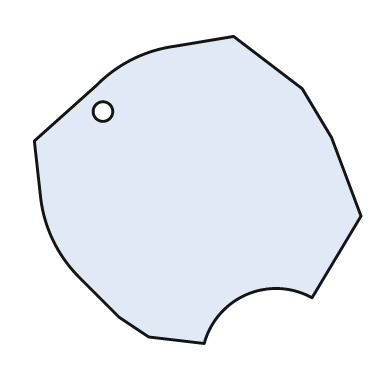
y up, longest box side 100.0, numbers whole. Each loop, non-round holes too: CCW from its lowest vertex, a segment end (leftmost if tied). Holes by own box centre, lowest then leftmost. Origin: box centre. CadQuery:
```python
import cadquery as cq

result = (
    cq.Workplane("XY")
    .moveTo(2.0, -47.0)
    .threePointArc((15.0, -32.0), (35.0, -33.0))
    .lineTo(50.0, -8.0)
    .lineTo(41.0, 16.0)
    .lineTo(32.0, 31.0)
    .lineTo(11.0, 47.0)
    .lineTo(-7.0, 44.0)
    .threePointArc((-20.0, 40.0), (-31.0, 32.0))
    .lineTo(-50.0, 15.0)
    .lineTo(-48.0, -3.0)
    .threePointArc((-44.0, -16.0), (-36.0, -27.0))
    .lineTo(-24.0, -39.0)
    .lineTo(-15.0, -45.0)
    .close()
    .moveTo(-29.0, 24.0)
    .circle(3.0)
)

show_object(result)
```